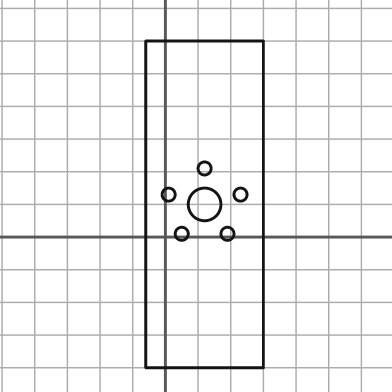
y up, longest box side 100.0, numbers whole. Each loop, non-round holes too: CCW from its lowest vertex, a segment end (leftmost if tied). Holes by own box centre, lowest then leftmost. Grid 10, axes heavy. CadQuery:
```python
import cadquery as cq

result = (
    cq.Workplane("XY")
    .moveTo(-6.0, -40.0)
    .lineTo(30.0, -40.0)
    .lineTo(30.0, 60.0)
    .lineTo(-6.0, 60.0)
    .close()
    .moveTo(5.0, 1.0)
    .circle(2.0)
    .moveTo(19.0, 1.0)
    .circle(2.0)
    .moveTo(12.0, 10.0)
    .circle(5.0)
    .moveTo(1.0, 13.0)
    .circle(2.0)
    .moveTo(23.0, 13.0)
    .circle(2.0)
    .moveTo(12.0, 21.0)
    .circle(2.0)
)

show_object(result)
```